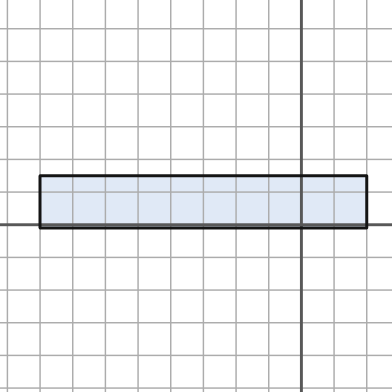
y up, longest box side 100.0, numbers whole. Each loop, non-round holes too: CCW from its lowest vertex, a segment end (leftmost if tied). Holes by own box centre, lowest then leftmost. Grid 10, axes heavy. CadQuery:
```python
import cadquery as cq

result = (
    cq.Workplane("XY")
    .moveTo(-80.0, -1.0)
    .lineTo(20.0, -1.0)
    .lineTo(20.0, 15.0)
    .lineTo(-80.0, 15.0)
    .close()
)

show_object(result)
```